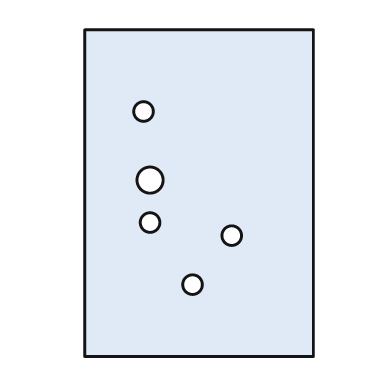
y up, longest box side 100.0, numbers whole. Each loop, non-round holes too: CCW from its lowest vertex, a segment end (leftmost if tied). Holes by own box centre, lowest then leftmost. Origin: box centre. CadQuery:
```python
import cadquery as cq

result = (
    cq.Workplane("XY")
    .moveTo(-35.0, -50.0)
    .lineTo(35.0, -50.0)
    .lineTo(35.0, 50.0)
    .lineTo(-35.0, 50.0)
    .close()
    .moveTo(-2.0, -28.0)
    .circle(3.0)
    .moveTo(10.0, -13.0)
    .circle(3.0)
    .moveTo(-15.0, -9.0)
    .circle(3.0)
    .moveTo(-15.0, 4.0)
    .circle(4.0)
    .moveTo(-17.0, 25.0)
    .circle(3.0)
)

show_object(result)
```